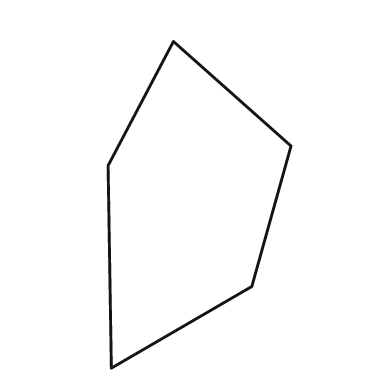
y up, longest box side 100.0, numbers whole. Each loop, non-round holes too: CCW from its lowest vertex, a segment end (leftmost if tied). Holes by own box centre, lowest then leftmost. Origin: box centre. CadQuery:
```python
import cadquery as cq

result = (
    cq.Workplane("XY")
    .moveTo(-27.0, -50.0)
    .lineTo(16.0, -25.0)
    .lineTo(28.0, 18.0)
    .lineTo(-8.0, 50.0)
    .lineTo(-28.0, 12.0)
    .close()
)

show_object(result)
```